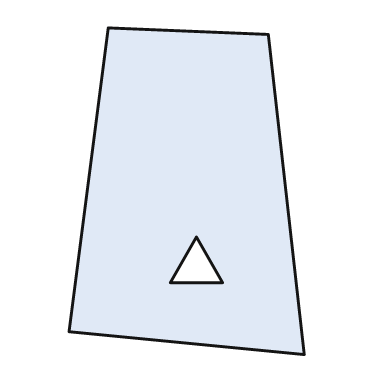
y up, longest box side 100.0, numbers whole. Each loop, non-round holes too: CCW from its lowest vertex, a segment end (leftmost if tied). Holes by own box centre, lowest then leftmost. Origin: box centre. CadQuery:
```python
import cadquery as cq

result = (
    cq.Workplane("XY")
    .moveTo(36.0, -50.0)
    .lineTo(25.0, 48.0)
    .lineTo(-24.0, 50.0)
    .lineTo(-36.0, -43.0)
    .close()
    .moveTo(-5.0, -28.0)
    .lineTo(11.0, -28.0)
    .lineTo(3.0, -14.0)
    .close()
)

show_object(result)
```